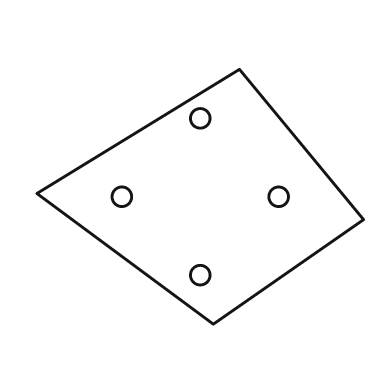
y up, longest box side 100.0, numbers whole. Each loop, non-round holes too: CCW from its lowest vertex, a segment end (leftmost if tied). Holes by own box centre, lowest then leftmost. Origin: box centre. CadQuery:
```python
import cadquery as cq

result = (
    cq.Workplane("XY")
    .moveTo(4.0, -39.0)
    .lineTo(50.0, -7.0)
    .lineTo(12.0, 39.0)
    .lineTo(-50.0, 1.0)
    .close()
    .moveTo(0.0, -24.0)
    .circle(3.0)
    .moveTo(-24.0, 0.0)
    .circle(3.0)
    .moveTo(24.0, 0.0)
    .circle(3.0)
    .moveTo(0.0, 24.0)
    .circle(3.0)
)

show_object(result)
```